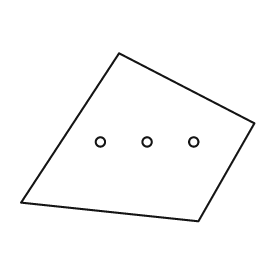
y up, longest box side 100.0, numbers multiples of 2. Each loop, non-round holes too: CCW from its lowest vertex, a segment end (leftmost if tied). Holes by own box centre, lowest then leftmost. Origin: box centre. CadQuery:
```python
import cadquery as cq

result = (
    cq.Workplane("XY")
    .moveTo(26.0, -36.0)
    .lineTo(50.0, 6.0)
    .lineTo(-8.0, 36.0)
    .lineTo(-50.0, -28.0)
    .close()
    .moveTo(-16.0, -2.0)
    .circle(2.0)
    .moveTo(4.0, -2.0)
    .circle(2.0)
    .moveTo(24.0, -2.0)
    .circle(2.0)
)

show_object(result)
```